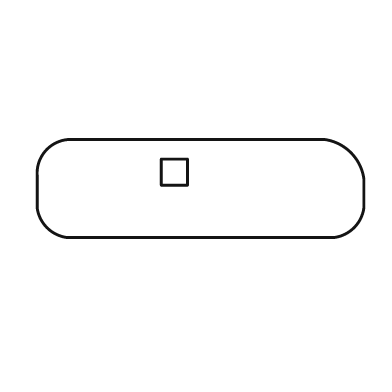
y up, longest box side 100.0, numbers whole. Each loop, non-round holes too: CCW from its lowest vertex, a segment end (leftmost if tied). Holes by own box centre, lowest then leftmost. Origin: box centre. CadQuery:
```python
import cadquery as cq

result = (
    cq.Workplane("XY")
    .moveTo(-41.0, -15.0)
    .lineTo(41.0, -15.0)
    .threePointArc((47.0, -12.0), (50.0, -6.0))
    .lineTo(50.0, 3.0)
    .threePointArc((46.0, 11.0), (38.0, 15.0))
    .lineTo(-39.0, 15.0)
    .threePointArc((-47.0, 12.0), (-50.0, 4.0))
    .lineTo(-50.0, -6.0)
    .threePointArc((-47.0, -12.0), (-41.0, -15.0))
    .close()
    .moveTo(-12.0, 1.0)
    .lineTo(-4.0, 1.0)
    .lineTo(-4.0, 9.0)
    .lineTo(-12.0, 9.0)
    .close()
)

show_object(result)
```